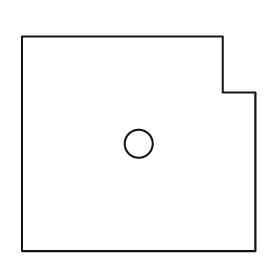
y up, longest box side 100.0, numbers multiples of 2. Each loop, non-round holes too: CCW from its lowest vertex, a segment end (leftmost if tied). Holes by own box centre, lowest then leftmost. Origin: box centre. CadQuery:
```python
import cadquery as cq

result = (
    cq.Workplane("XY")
    .moveTo(-50.0, -46.0)
    .lineTo(50.0, -46.0)
    .lineTo(50.0, 22.0)
    .lineTo(36.0, 22.0)
    .lineTo(36.0, 46.0)
    .lineTo(-50.0, 46.0)
    .close()
    .moveTo(0.0, 0.0)
    .circle(6.0)
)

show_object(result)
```